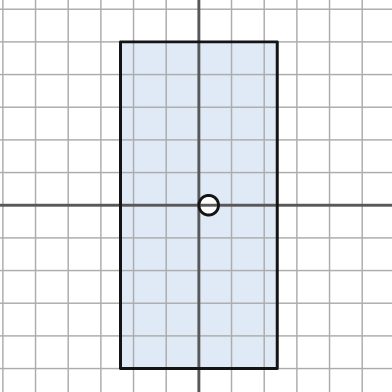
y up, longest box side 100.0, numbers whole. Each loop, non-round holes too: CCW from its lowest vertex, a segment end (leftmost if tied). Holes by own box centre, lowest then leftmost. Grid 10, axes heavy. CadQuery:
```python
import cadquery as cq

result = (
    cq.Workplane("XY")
    .moveTo(-24.0, -50.0)
    .lineTo(24.0, -50.0)
    .lineTo(24.0, 50.0)
    .lineTo(-24.0, 50.0)
    .close()
    .moveTo(3.0, 0.0)
    .circle(3.0)
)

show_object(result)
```